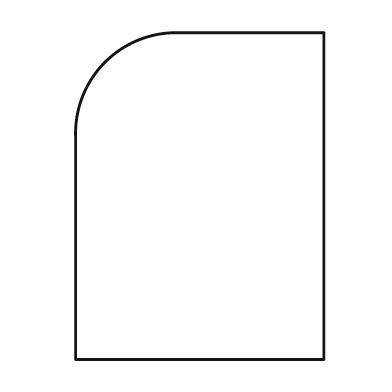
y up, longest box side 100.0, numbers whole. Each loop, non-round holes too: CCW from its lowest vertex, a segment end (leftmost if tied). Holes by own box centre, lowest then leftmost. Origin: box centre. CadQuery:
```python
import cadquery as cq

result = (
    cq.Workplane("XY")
    .moveTo(-38.0, -50.0)
    .lineTo(38.0, -50.0)
    .lineTo(38.0, 50.0)
    .lineTo(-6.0, 50.0)
    .threePointArc((-29.0, 41.0), (-38.0, 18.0))
    .close()
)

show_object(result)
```